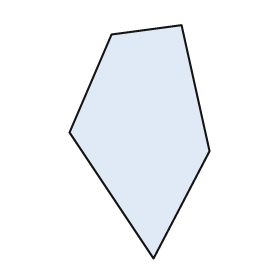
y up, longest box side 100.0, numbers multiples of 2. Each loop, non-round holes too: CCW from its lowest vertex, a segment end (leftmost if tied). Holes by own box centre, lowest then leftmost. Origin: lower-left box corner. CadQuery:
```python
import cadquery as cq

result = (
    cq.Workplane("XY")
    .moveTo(36.0, 0.0)
    .lineTo(60.0, 46.0)
    .lineTo(48.0, 100.0)
    .lineTo(18.0, 96.0)
    .lineTo(0.0, 54.0)
    .close()
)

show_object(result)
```